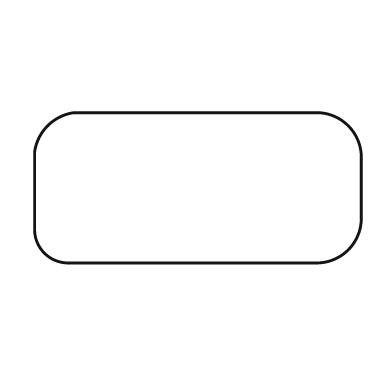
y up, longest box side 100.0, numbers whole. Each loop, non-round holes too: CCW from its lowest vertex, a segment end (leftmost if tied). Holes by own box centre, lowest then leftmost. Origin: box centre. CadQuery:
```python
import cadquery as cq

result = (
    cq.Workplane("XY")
    .moveTo(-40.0, -23.0)
    .lineTo(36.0, -23.0)
    .threePointArc((46.0, -19.0), (50.0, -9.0))
    .lineTo(50.0, 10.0)
    .threePointArc((46.0, 19.0), (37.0, 23.0))
    .lineTo(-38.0, 23.0)
    .threePointArc((-46.0, 19.0), (-50.0, 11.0))
    .lineTo(-50.0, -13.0)
    .threePointArc((-47.0, -20.0), (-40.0, -23.0))
    .close()
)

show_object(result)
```